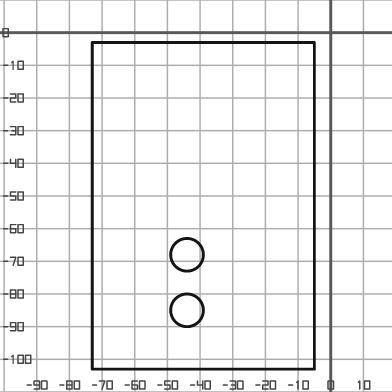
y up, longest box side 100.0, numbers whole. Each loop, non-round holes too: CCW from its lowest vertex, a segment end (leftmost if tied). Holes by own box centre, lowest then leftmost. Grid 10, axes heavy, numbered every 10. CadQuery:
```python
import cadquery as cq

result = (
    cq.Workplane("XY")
    .moveTo(-73.0, -103.0)
    .lineTo(-5.0, -103.0)
    .lineTo(-5.0, -3.0)
    .lineTo(-73.0, -3.0)
    .close()
    .moveTo(-44.0, -85.0)
    .circle(5.0)
    .moveTo(-44.0, -68.0)
    .circle(5.0)
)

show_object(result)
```